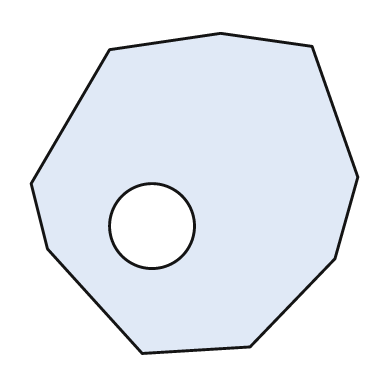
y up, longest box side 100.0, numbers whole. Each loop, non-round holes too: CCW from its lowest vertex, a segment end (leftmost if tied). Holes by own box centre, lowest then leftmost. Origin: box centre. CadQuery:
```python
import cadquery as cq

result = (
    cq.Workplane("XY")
    .moveTo(-16.0, -49.0)
    .lineTo(17.0, -47.0)
    .lineTo(43.0, -20.0)
    .lineTo(50.0, 5.0)
    .lineTo(36.0, 45.0)
    .lineTo(8.0, 49.0)
    .lineTo(-26.0, 44.0)
    .lineTo(-50.0, 3.0)
    .lineTo(-45.0, -17.0)
    .close()
    .moveTo(-13.0, -10.0)
    .circle(13.0)
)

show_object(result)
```